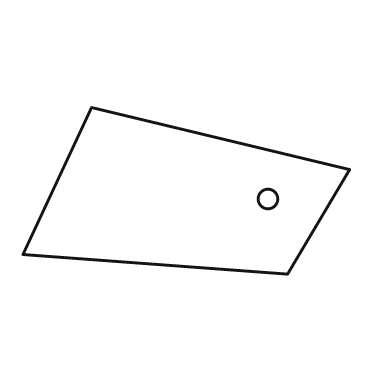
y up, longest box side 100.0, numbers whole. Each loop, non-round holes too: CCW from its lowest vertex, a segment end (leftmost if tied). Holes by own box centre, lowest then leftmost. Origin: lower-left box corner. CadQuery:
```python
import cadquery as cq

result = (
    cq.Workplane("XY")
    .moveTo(81.0, 0.0)
    .lineTo(100.0, 32.0)
    .lineTo(21.0, 51.0)
    .lineTo(0.0, 6.0)
    .close()
    .moveTo(75.0, 23.0)
    .circle(3.0)
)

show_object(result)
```